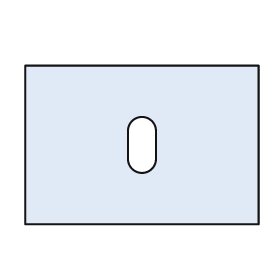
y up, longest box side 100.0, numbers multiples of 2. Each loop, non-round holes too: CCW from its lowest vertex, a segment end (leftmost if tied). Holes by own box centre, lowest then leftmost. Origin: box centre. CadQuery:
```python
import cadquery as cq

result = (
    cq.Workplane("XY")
    .moveTo(-50.0, -34.0)
    .lineTo(50.0, -34.0)
    .lineTo(50.0, 34.0)
    .lineTo(-50.0, 34.0)
    .close()
    .moveTo(-6.0, -6.0)
    .threePointArc((0.0, -12.0), (6.0, -6.0))
    .lineTo(6.0, 6.0)
    .threePointArc((0.0, 12.0), (-6.0, 6.0))
    .close()
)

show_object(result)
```